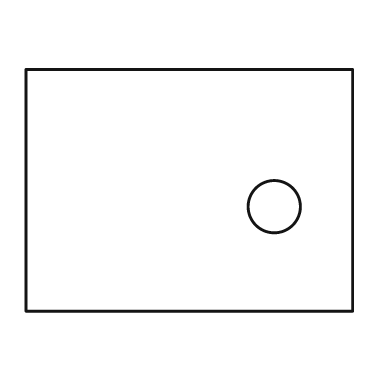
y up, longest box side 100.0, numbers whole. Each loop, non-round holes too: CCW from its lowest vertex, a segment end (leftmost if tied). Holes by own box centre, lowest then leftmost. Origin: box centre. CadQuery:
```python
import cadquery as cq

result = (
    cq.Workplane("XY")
    .moveTo(-50.0, -37.0)
    .lineTo(50.0, -37.0)
    .lineTo(50.0, 37.0)
    .lineTo(-50.0, 37.0)
    .close()
    .moveTo(26.0, -5.0)
    .circle(8.0)
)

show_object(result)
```